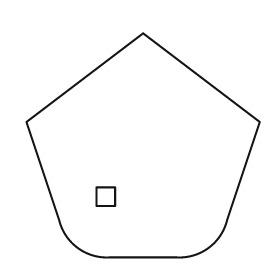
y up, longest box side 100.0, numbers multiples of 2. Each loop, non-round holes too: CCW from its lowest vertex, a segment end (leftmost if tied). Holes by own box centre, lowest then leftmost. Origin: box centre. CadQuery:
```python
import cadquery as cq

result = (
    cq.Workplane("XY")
    .moveTo(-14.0, -48.0)
    .lineTo(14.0, -48.0)
    .threePointArc((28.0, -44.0), (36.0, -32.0))
    .lineTo(50.0, 10.0)
    .lineTo(0.0, 48.0)
    .lineTo(-50.0, 10.0)
    .lineTo(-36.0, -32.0)
    .threePointArc((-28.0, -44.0), (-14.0, -48.0))
    .close()
    .moveTo(-20.0, -26.0)
    .lineTo(-12.0, -26.0)
    .lineTo(-12.0, -18.0)
    .lineTo(-20.0, -18.0)
    .close()
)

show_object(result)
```